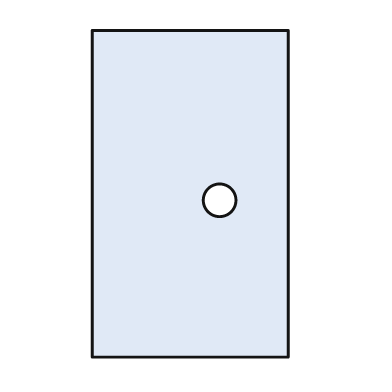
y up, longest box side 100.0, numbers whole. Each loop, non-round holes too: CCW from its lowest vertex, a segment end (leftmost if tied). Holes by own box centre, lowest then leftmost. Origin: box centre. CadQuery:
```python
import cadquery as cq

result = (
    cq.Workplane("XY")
    .moveTo(-30.0, -50.0)
    .lineTo(30.0, -50.0)
    .lineTo(30.0, 50.0)
    .lineTo(-30.0, 50.0)
    .close()
    .moveTo(9.0, -2.0)
    .circle(5.0)
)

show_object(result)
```